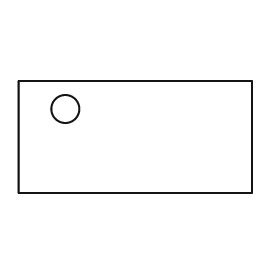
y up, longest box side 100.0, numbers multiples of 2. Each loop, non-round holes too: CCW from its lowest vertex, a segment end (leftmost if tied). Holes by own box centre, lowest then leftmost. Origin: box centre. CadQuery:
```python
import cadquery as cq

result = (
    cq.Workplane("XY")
    .moveTo(-50.0, -24.0)
    .lineTo(50.0, -24.0)
    .lineTo(50.0, 24.0)
    .lineTo(-50.0, 24.0)
    .close()
    .moveTo(-30.0, 12.0)
    .circle(6.0)
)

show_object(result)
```